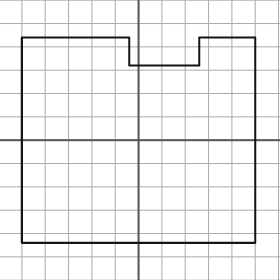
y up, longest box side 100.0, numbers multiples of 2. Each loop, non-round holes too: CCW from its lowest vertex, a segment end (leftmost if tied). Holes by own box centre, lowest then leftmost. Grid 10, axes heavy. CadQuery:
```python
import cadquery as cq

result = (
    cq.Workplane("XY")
    .moveTo(-50.0, -44.0)
    .lineTo(50.0, -44.0)
    .lineTo(50.0, 44.0)
    .lineTo(26.0, 44.0)
    .lineTo(26.0, 32.0)
    .lineTo(-4.0, 32.0)
    .lineTo(-4.0, 44.0)
    .lineTo(-50.0, 44.0)
    .close()
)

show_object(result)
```